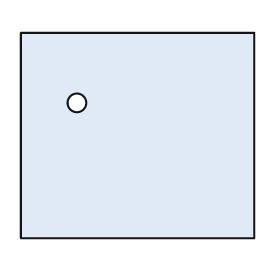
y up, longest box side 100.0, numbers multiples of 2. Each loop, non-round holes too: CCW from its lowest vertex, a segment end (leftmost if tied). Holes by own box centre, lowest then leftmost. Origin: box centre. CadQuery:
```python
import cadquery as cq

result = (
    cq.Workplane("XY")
    .moveTo(-50.0, -44.0)
    .lineTo(50.0, -44.0)
    .lineTo(50.0, 44.0)
    .lineTo(-50.0, 44.0)
    .close()
    .moveTo(-26.0, 14.0)
    .circle(4.0)
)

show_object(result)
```